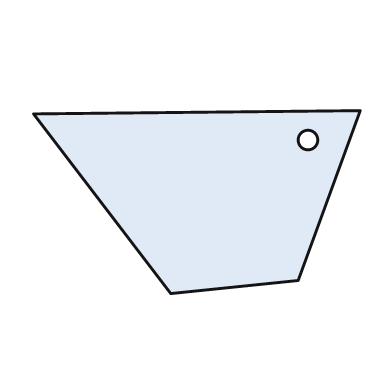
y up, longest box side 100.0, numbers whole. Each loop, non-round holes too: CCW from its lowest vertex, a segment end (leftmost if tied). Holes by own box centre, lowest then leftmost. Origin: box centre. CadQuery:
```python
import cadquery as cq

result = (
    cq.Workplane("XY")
    .moveTo(-8.0, -28.0)
    .lineTo(31.0, -24.0)
    .lineTo(50.0, 28.0)
    .lineTo(-50.0, 27.0)
    .close()
    .moveTo(34.0, 19.0)
    .circle(3.0)
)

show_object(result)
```